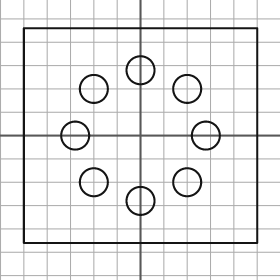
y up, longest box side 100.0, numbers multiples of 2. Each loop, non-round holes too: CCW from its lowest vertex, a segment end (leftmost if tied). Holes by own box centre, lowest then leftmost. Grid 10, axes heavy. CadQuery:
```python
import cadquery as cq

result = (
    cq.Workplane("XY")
    .moveTo(-50.0, -46.0)
    .lineTo(50.0, -46.0)
    .lineTo(50.0, 46.0)
    .lineTo(-50.0, 46.0)
    .close()
    .moveTo(0.0, -28.0)
    .circle(6.0)
    .moveTo(-20.0, -20.0)
    .circle(6.0)
    .moveTo(20.0, -20.0)
    .circle(6.0)
    .moveTo(-28.0, 0.0)
    .circle(6.0)
    .moveTo(28.0, 0.0)
    .circle(6.0)
    .moveTo(-20.0, 20.0)
    .circle(6.0)
    .moveTo(20.0, 20.0)
    .circle(6.0)
    .moveTo(0.0, 28.0)
    .circle(6.0)
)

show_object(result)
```